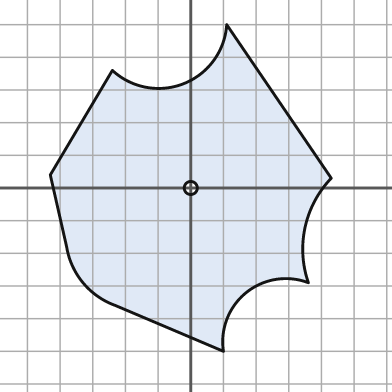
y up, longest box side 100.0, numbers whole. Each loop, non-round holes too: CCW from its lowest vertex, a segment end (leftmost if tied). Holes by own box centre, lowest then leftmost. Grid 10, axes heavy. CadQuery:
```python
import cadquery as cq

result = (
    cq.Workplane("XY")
    .moveTo(10.0, -50.0)
    .threePointArc((17.0, -32.0), (36.0, -29.0))
    .threePointArc((35.0, -12.0), (43.0, 3.0))
    .lineTo(11.0, 50.0)
    .threePointArc((-2.0, 32.0), (-24.0, 36.0))
    .lineTo(-43.0, 4.0)
    .lineTo(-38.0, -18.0)
    .threePointArc((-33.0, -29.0), (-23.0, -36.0))
    .close()
    .moveTo(0.0, 0.0)
    .circle(2.0)
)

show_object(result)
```